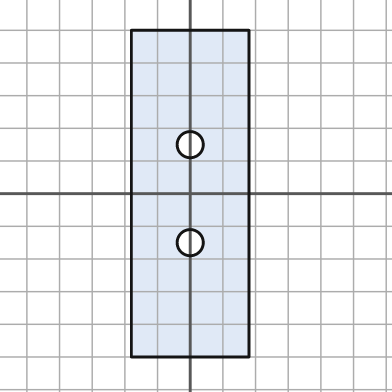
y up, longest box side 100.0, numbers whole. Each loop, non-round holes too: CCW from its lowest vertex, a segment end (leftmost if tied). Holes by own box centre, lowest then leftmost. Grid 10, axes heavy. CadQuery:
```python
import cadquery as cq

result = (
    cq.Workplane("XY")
    .moveTo(-18.0, -50.0)
    .lineTo(18.0, -50.0)
    .lineTo(18.0, 50.0)
    .lineTo(-18.0, 50.0)
    .close()
    .moveTo(0.0, -15.0)
    .circle(4.0)
    .moveTo(0.0, 15.0)
    .circle(4.0)
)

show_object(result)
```